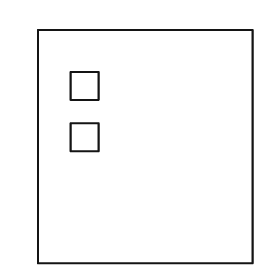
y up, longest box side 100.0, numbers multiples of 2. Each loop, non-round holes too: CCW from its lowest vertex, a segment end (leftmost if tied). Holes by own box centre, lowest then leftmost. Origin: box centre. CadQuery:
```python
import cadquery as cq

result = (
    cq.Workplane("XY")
    .moveTo(-46.0, -50.0)
    .lineTo(46.0, -50.0)
    .lineTo(46.0, 50.0)
    .lineTo(-46.0, 50.0)
    .close()
    .moveTo(-32.0, -2.0)
    .lineTo(-20.0, -2.0)
    .lineTo(-20.0, 10.0)
    .lineTo(-32.0, 10.0)
    .close()
    .moveTo(-32.0, 20.0)
    .lineTo(-20.0, 20.0)
    .lineTo(-20.0, 32.0)
    .lineTo(-32.0, 32.0)
    .close()
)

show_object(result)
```